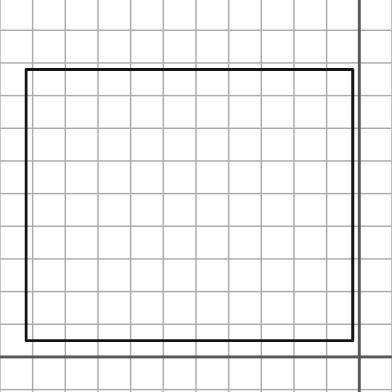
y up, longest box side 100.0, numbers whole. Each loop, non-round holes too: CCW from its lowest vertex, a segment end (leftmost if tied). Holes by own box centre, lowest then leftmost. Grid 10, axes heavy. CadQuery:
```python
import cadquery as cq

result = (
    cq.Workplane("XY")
    .moveTo(-102.0, 5.0)
    .lineTo(-2.0, 5.0)
    .lineTo(-2.0, 88.0)
    .lineTo(-102.0, 88.0)
    .close()
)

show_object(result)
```